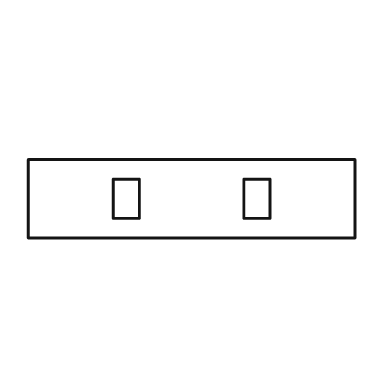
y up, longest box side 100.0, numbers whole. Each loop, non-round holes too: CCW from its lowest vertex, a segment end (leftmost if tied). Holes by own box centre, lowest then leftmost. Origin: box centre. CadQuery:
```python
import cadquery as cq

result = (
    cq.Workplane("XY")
    .moveTo(-50.0, -12.0)
    .lineTo(50.0, -12.0)
    .lineTo(50.0, 12.0)
    .lineTo(-50.0, 12.0)
    .close()
    .moveTo(-24.0, -6.0)
    .lineTo(-16.0, -6.0)
    .lineTo(-16.0, 6.0)
    .lineTo(-24.0, 6.0)
    .close()
    .moveTo(16.0, -6.0)
    .lineTo(24.0, -6.0)
    .lineTo(24.0, 6.0)
    .lineTo(16.0, 6.0)
    .close()
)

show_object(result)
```